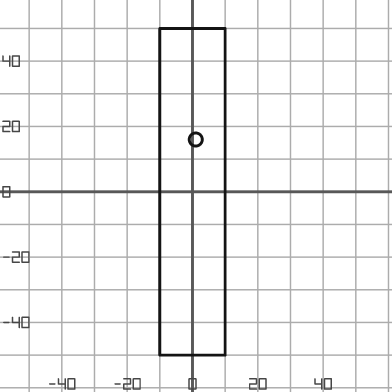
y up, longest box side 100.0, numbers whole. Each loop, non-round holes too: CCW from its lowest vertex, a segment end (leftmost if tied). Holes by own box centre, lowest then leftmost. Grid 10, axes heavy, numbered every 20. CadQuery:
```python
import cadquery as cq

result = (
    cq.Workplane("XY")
    .moveTo(-10.0, -50.0)
    .lineTo(10.0, -50.0)
    .lineTo(10.0, 50.0)
    .lineTo(-10.0, 50.0)
    .close()
    .moveTo(1.0, 16.0)
    .circle(2.0)
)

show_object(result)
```